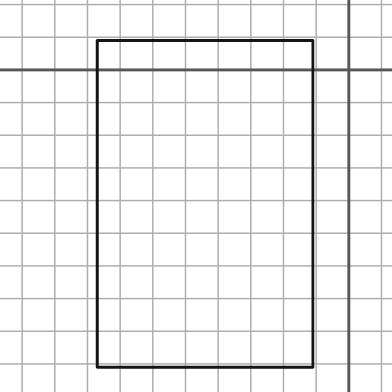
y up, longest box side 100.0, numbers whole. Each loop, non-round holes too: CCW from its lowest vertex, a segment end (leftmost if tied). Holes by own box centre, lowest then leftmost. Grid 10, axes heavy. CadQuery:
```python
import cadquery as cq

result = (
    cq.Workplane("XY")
    .moveTo(-77.0, -91.0)
    .lineTo(-11.0, -91.0)
    .lineTo(-11.0, 9.0)
    .lineTo(-77.0, 9.0)
    .close()
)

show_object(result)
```